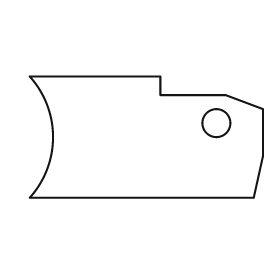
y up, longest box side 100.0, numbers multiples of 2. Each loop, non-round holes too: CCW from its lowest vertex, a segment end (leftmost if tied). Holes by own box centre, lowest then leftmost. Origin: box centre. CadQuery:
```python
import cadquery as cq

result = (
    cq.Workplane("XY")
    .moveTo(-50.0, -26.0)
    .lineTo(46.0, -26.0)
    .lineTo(50.0, -8.0)
    .lineTo(50.0, 12.0)
    .lineTo(34.0, 18.0)
    .lineTo(6.0, 18.0)
    .lineTo(6.0, 26.0)
    .lineTo(-50.0, 26.0)
    .threePointArc((-40.0, 0.0), (-50.0, -26.0))
    .close()
    .moveTo(30.0, 6.0)
    .circle(6.0)
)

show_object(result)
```